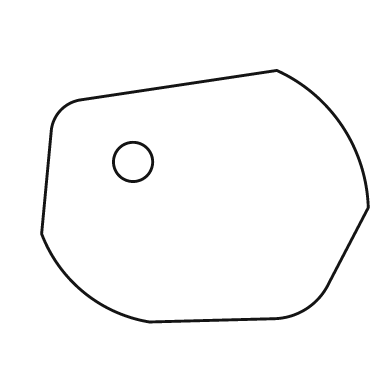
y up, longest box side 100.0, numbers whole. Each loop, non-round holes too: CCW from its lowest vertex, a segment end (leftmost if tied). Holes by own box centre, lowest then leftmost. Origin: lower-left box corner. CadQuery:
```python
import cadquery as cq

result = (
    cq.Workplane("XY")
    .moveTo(33.0, 0.0)
    .lineTo(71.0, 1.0)
    .threePointArc((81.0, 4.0), (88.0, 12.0))
    .lineTo(100.0, 35.0)
    .threePointArc((92.0, 60.0), (72.0, 77.0))
    .lineTo(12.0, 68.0)
    .threePointArc((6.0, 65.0), (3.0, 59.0))
    .lineTo(0.0, 27.0)
    .threePointArc((13.0, 9.0), (33.0, 0.0))
    .close()
    .moveTo(28.0, 49.0)
    .circle(6.0)
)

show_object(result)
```